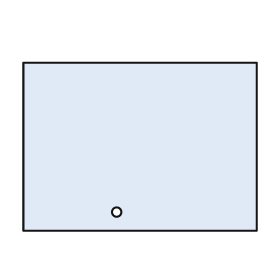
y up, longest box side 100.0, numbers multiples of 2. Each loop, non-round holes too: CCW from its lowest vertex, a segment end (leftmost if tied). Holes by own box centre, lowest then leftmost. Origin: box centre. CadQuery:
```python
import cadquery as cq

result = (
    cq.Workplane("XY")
    .moveTo(-50.0, -36.0)
    .lineTo(50.0, -36.0)
    .lineTo(50.0, 36.0)
    .lineTo(-50.0, 36.0)
    .close()
    .moveTo(-10.0, -28.0)
    .circle(2.0)
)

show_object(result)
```